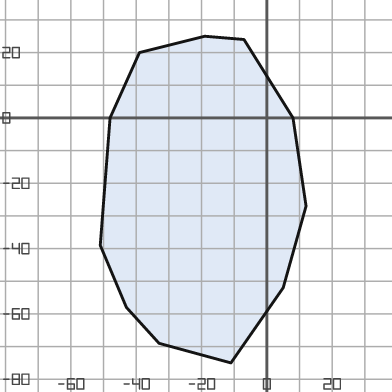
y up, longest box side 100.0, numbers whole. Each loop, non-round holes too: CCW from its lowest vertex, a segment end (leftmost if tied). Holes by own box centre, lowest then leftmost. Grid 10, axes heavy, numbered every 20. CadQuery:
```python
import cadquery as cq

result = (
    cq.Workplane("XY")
    .moveTo(-11.0, -75.0)
    .lineTo(5.0, -52.0)
    .lineTo(12.0, -27.0)
    .lineTo(8.0, 0.0)
    .lineTo(-7.0, 24.0)
    .lineTo(-19.0, 25.0)
    .lineTo(-39.0, 20.0)
    .lineTo(-48.0, 0.0)
    .lineTo(-51.0, -39.0)
    .lineTo(-43.0, -58.0)
    .lineTo(-33.0, -69.0)
    .close()
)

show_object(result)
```